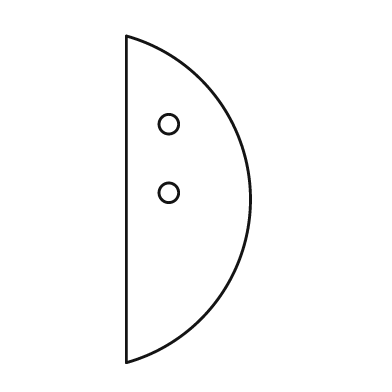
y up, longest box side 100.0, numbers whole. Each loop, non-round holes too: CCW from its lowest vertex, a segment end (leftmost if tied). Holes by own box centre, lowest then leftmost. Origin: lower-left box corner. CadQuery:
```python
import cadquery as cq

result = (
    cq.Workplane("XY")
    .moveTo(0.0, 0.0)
    .threePointArc((38.0, 50.0), (0.0, 100.0))
    .close()
    .moveTo(13.0, 52.0)
    .circle(3.0)
    .moveTo(13.0, 73.0)
    .circle(3.0)
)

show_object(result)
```